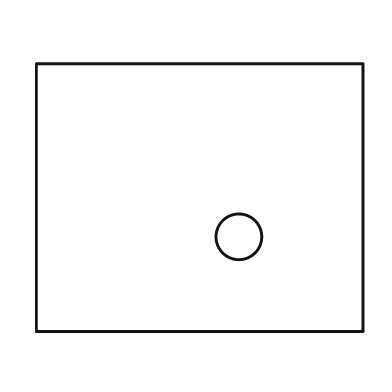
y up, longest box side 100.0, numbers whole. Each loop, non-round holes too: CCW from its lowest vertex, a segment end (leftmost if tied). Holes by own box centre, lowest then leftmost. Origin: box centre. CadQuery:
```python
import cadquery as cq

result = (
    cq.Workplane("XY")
    .moveTo(-50.0, -41.0)
    .lineTo(50.0, -41.0)
    .lineTo(50.0, 41.0)
    .lineTo(-50.0, 41.0)
    .close()
    .moveTo(12.0, -12.0)
    .circle(7.0)
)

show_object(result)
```